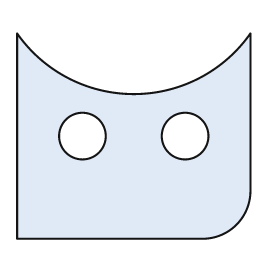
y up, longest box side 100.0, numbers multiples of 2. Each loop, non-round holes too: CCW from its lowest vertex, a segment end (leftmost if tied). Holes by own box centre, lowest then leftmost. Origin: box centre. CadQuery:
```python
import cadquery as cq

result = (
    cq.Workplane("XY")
    .moveTo(-50.0, -44.0)
    .lineTo(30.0, -44.0)
    .threePointArc((44.0, -38.0), (50.0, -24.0))
    .lineTo(50.0, 44.0)
    .threePointArc((0.0, 18.0), (-50.0, 44.0))
    .close()
    .moveTo(-22.0, 0.0)
    .circle(10.0)
    .moveTo(22.0, 0.0)
    .circle(10.0)
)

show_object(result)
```